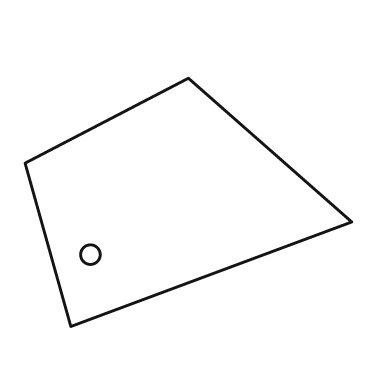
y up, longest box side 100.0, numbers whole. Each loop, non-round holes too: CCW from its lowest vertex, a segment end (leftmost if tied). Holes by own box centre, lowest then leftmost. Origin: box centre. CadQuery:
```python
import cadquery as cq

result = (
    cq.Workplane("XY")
    .moveTo(-36.0, -38.0)
    .lineTo(50.0, -6.0)
    .lineTo(0.0, 38.0)
    .lineTo(-50.0, 12.0)
    .close()
    .moveTo(-30.0, -16.0)
    .circle(3.0)
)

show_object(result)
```